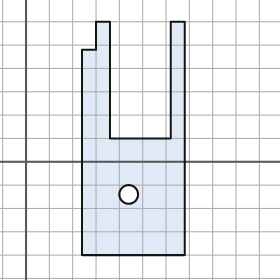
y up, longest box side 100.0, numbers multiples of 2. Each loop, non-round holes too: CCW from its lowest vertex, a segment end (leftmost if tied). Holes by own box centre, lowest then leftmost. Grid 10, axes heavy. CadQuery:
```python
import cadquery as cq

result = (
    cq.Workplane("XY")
    .moveTo(24.0, -40.0)
    .lineTo(68.0, -40.0)
    .lineTo(68.0, 60.0)
    .lineTo(62.0, 60.0)
    .lineTo(62.0, 10.0)
    .lineTo(36.0, 10.0)
    .lineTo(36.0, 60.0)
    .lineTo(30.0, 60.0)
    .lineTo(30.0, 48.0)
    .lineTo(24.0, 48.0)
    .close()
    .moveTo(44.0, -14.0)
    .circle(4.0)
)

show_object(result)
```